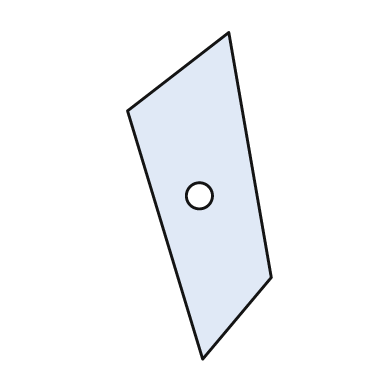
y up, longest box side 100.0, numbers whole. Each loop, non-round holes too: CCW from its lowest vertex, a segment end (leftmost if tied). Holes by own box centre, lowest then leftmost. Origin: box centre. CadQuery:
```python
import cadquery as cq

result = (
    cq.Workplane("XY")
    .moveTo(1.0, -50.0)
    .lineTo(22.0, -25.0)
    .lineTo(9.0, 50.0)
    .lineTo(-22.0, 26.0)
    .close()
    .moveTo(0.0, 0.0)
    .circle(4.0)
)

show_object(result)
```